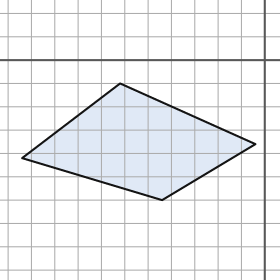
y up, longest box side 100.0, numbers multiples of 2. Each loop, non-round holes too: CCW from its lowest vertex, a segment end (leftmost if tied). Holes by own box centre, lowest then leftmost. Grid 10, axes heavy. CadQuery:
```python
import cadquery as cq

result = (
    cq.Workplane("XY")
    .moveTo(-44.0, -60.0)
    .lineTo(-4.0, -36.0)
    .lineTo(-62.0, -10.0)
    .lineTo(-104.0, -42.0)
    .close()
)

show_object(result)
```